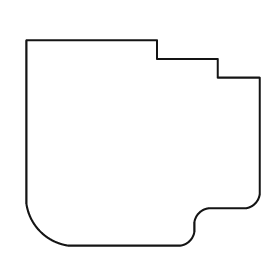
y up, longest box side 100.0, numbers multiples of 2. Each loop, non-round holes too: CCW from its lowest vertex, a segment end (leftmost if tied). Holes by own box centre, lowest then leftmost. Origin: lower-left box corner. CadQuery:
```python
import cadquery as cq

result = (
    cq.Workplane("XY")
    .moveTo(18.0, 0.0)
    .lineTo(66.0, 0.0)
    .threePointArc((70.0, 2.0), (72.0, 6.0))
    .lineTo(72.0, 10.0)
    .threePointArc((74.0, 14.0), (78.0, 16.0))
    .lineTo(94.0, 16.0)
    .threePointArc((98.0, 18.0), (100.0, 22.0))
    .lineTo(100.0, 72.0)
    .lineTo(82.0, 72.0)
    .lineTo(82.0, 80.0)
    .lineTo(56.0, 80.0)
    .lineTo(56.0, 88.0)
    .lineTo(0.0, 88.0)
    .lineTo(0.0, 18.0)
    .threePointArc((6.0, 6.0), (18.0, 0.0))
    .close()
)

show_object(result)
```